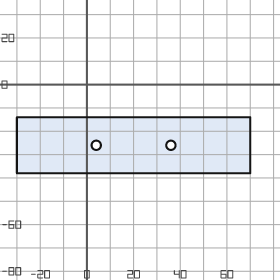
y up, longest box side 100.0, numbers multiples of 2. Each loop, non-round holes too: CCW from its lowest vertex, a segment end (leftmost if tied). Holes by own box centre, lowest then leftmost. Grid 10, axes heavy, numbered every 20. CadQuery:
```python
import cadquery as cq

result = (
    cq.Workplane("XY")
    .moveTo(-30.0, -38.0)
    .lineTo(70.0, -38.0)
    .lineTo(70.0, -14.0)
    .lineTo(-30.0, -14.0)
    .close()
    .moveTo(4.0, -26.0)
    .circle(2.0)
    .moveTo(36.0, -26.0)
    .circle(2.0)
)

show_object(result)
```